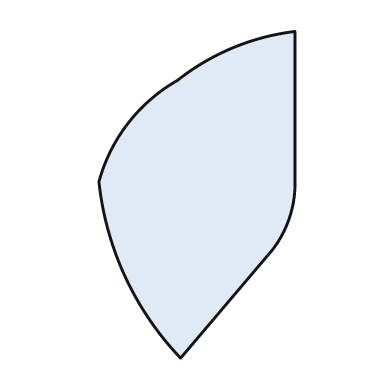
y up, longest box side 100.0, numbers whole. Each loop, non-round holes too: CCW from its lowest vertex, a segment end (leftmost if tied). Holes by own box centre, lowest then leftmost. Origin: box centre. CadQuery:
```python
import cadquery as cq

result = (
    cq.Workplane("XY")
    .moveTo(-5.0, -50.0)
    .lineTo(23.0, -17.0)
    .threePointArc((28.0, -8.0), (30.0, 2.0))
    .lineTo(30.0, 50.0)
    .threePointArc((11.0, 45.0), (-6.0, 35.0))
    .threePointArc((-21.0, 22.0), (-30.0, 4.0))
    .threePointArc((-22.0, -25.0), (-5.0, -50.0))
    .close()
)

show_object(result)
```